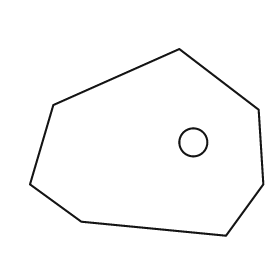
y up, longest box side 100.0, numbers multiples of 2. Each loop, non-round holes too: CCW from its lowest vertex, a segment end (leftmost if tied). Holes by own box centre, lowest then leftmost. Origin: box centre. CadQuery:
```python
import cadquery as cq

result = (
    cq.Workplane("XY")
    .moveTo(34.0, -40.0)
    .lineTo(50.0, -18.0)
    .lineTo(48.0, 14.0)
    .lineTo(14.0, 40.0)
    .lineTo(-40.0, 16.0)
    .lineTo(-50.0, -18.0)
    .lineTo(-28.0, -34.0)
    .close()
    .moveTo(20.0, 0.0)
    .circle(6.0)
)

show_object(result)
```